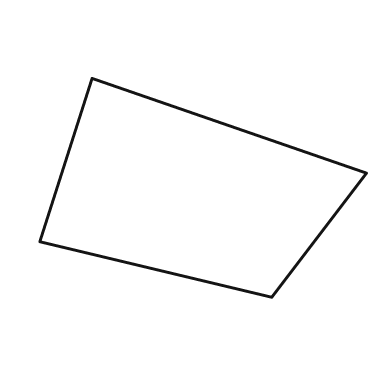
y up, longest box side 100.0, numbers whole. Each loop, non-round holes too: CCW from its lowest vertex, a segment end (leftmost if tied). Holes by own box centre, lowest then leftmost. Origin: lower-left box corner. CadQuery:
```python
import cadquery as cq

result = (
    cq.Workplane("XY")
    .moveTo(71.0, 0.0)
    .lineTo(100.0, 38.0)
    .lineTo(16.0, 67.0)
    .lineTo(0.0, 17.0)
    .close()
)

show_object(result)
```